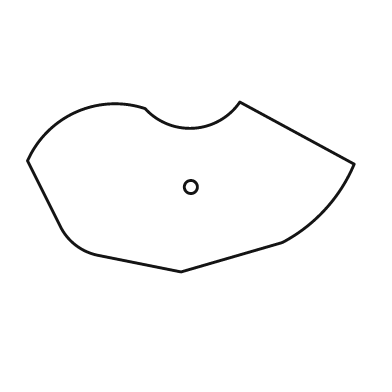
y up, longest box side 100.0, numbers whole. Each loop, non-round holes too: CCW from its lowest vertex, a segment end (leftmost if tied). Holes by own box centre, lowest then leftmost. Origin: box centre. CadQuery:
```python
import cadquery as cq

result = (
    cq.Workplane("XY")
    .moveTo(-3.0, -26.0)
    .lineTo(28.0, -17.0)
    .threePointArc((41.0, -7.0), (50.0, 7.0))
    .lineTo(15.0, 26.0)
    .threePointArc((1.0, 18.0), (-14.0, 24.0))
    .threePointArc((-35.0, 23.0), (-50.0, 8.0))
    .lineTo(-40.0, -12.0)
    .threePointArc((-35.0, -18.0), (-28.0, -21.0))
    .close()
    .moveTo(0.0, 0.0)
    .circle(2.0)
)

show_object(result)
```